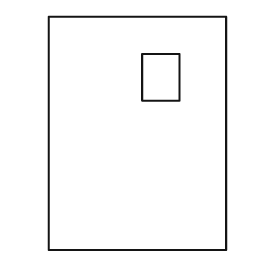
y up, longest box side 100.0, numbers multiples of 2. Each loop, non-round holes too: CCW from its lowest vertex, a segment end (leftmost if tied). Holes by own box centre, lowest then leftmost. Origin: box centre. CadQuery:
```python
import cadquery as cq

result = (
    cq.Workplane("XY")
    .moveTo(-38.0, -50.0)
    .lineTo(38.0, -50.0)
    .lineTo(38.0, 50.0)
    .lineTo(-38.0, 50.0)
    .close()
    .moveTo(2.0, 14.0)
    .lineTo(18.0, 14.0)
    .lineTo(18.0, 34.0)
    .lineTo(2.0, 34.0)
    .close()
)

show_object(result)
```